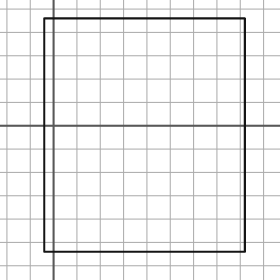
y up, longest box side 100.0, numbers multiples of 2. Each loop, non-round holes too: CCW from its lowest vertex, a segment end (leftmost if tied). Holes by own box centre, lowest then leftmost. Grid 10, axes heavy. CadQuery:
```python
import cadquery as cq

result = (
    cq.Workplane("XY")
    .moveTo(-4.0, -54.0)
    .lineTo(82.0, -54.0)
    .lineTo(82.0, 46.0)
    .lineTo(-4.0, 46.0)
    .close()
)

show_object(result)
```